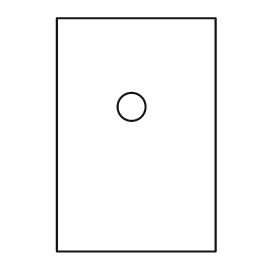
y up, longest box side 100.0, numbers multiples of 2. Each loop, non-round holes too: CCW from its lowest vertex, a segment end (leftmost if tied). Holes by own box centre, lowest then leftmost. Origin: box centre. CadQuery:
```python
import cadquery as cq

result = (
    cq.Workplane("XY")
    .moveTo(-34.0, -50.0)
    .lineTo(34.0, -50.0)
    .lineTo(34.0, 50.0)
    .lineTo(-34.0, 50.0)
    .close()
    .moveTo(-2.0, 12.0)
    .circle(6.0)
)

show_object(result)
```